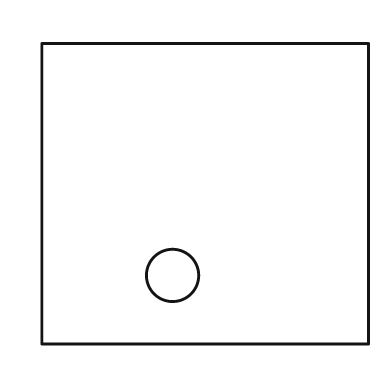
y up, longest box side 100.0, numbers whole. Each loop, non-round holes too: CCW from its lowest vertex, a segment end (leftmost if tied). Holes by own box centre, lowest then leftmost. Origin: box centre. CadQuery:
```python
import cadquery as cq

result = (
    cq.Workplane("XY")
    .moveTo(-50.0, -46.0)
    .lineTo(50.0, -46.0)
    .lineTo(50.0, 46.0)
    .lineTo(-50.0, 46.0)
    .close()
    .moveTo(-10.0, -25.0)
    .circle(8.0)
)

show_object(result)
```